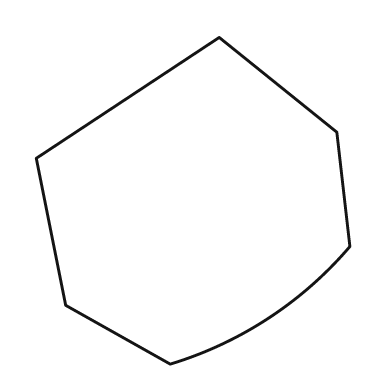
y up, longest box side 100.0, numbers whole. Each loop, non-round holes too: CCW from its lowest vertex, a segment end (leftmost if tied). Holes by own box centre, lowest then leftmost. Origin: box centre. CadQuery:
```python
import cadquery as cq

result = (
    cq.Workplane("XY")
    .moveTo(-7.0, -50.0)
    .threePointArc((23.0, -36.0), (48.0, -14.0))
    .lineTo(44.0, 21.0)
    .lineTo(8.0, 50.0)
    .lineTo(-48.0, 13.0)
    .lineTo(-39.0, -32.0)
    .close()
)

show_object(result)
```